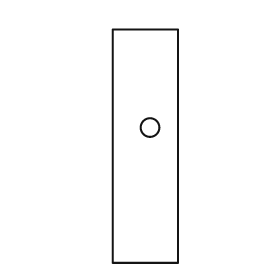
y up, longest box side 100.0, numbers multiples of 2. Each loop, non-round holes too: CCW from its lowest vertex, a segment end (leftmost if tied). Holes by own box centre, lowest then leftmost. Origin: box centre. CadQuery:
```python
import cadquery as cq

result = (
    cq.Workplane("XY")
    .moveTo(-14.0, -50.0)
    .lineTo(14.0, -50.0)
    .lineTo(14.0, 50.0)
    .lineTo(-14.0, 50.0)
    .close()
    .moveTo(2.0, 8.0)
    .circle(4.0)
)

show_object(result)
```